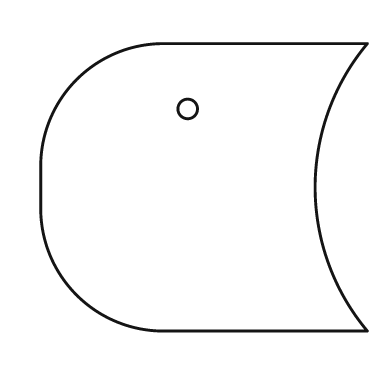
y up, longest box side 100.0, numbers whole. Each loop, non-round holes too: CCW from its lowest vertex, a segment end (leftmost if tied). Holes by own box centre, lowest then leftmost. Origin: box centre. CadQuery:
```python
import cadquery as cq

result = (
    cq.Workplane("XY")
    .moveTo(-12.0, -44.0)
    .lineTo(50.0, -44.0)
    .threePointArc((34.0, 0.0), (50.0, 44.0))
    .lineTo(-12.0, 44.0)
    .threePointArc((-39.0, 33.0), (-50.0, 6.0))
    .lineTo(-50.0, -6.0)
    .threePointArc((-39.0, -33.0), (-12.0, -44.0))
    .close()
    .moveTo(-5.0, 24.0)
    .circle(3.0)
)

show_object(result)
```